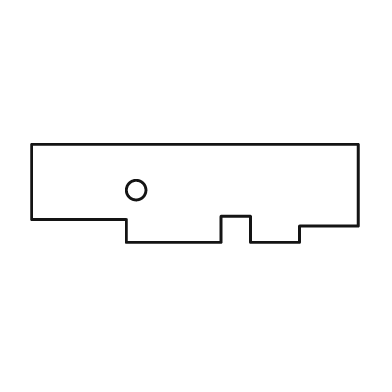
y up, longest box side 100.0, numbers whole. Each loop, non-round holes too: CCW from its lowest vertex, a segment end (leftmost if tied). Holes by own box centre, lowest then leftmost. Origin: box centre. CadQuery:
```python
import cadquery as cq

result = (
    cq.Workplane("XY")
    .moveTo(-21.0, -15.0)
    .lineTo(8.0, -15.0)
    .lineTo(8.0, -7.0)
    .lineTo(17.0, -7.0)
    .lineTo(17.0, -15.0)
    .lineTo(32.0, -15.0)
    .lineTo(32.0, -10.0)
    .lineTo(50.0, -10.0)
    .lineTo(50.0, 15.0)
    .lineTo(-50.0, 15.0)
    .lineTo(-50.0, -8.0)
    .lineTo(-21.0, -8.0)
    .close()
    .moveTo(-18.0, 1.0)
    .circle(3.0)
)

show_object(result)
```